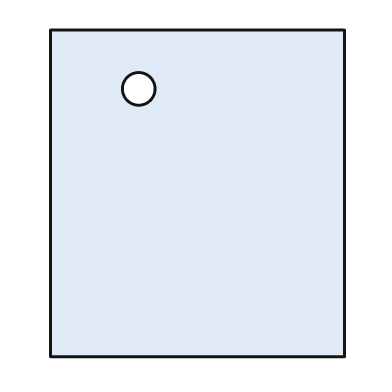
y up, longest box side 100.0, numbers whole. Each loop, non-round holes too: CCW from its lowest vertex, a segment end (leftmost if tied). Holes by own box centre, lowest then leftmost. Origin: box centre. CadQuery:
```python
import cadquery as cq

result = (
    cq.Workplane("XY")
    .moveTo(-45.0, -50.0)
    .lineTo(45.0, -50.0)
    .lineTo(45.0, 50.0)
    .lineTo(-45.0, 50.0)
    .close()
    .moveTo(-18.0, 32.0)
    .circle(5.0)
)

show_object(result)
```